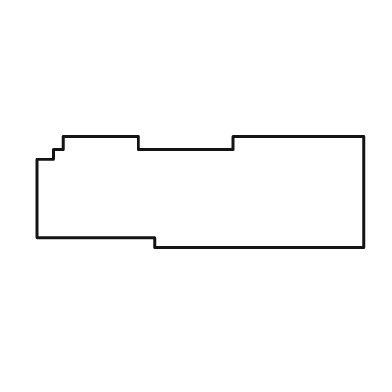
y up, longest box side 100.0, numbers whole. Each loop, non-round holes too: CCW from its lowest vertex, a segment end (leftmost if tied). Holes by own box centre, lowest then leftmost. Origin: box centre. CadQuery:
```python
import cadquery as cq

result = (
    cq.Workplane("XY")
    .moveTo(-14.0, -17.0)
    .lineTo(50.0, -17.0)
    .lineTo(50.0, 17.0)
    .lineTo(10.0, 17.0)
    .lineTo(10.0, 13.0)
    .lineTo(-19.0, 13.0)
    .lineTo(-19.0, 17.0)
    .lineTo(-42.0, 17.0)
    .lineTo(-42.0, 13.0)
    .lineTo(-45.0, 13.0)
    .lineTo(-45.0, 10.0)
    .lineTo(-50.0, 10.0)
    .lineTo(-50.0, -14.0)
    .lineTo(-14.0, -14.0)
    .close()
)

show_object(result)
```